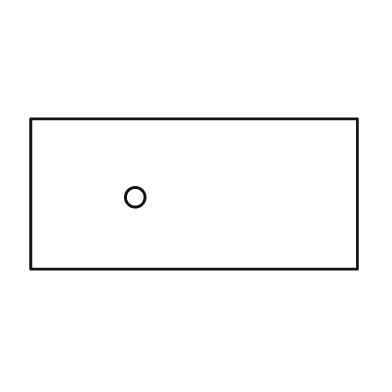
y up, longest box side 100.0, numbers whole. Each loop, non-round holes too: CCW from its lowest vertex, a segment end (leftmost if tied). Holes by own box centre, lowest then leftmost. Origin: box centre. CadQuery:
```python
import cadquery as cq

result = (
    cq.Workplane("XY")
    .moveTo(-50.0, -23.0)
    .lineTo(50.0, -23.0)
    .lineTo(50.0, 23.0)
    .lineTo(-50.0, 23.0)
    .close()
    .moveTo(-18.0, -1.0)
    .circle(3.0)
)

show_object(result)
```